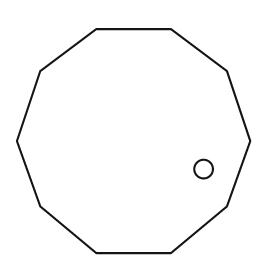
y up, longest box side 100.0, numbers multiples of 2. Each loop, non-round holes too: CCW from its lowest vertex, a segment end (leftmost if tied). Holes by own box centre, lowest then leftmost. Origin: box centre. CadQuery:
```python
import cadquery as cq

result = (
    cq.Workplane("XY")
    .moveTo(-16.0, -48.0)
    .lineTo(16.0, -48.0)
    .lineTo(40.0, -28.0)
    .lineTo(50.0, 0.0)
    .lineTo(40.0, 30.0)
    .lineTo(16.0, 48.0)
    .lineTo(-16.0, 48.0)
    .lineTo(-40.0, 30.0)
    .lineTo(-50.0, 0.0)
    .lineTo(-40.0, -28.0)
    .close()
    .moveTo(30.0, -12.0)
    .circle(4.0)
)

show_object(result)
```